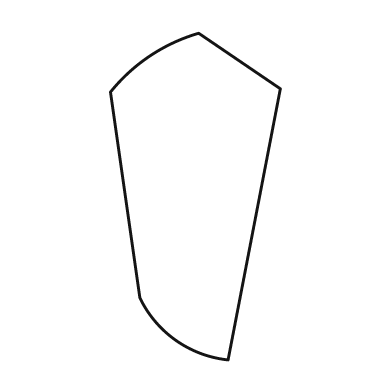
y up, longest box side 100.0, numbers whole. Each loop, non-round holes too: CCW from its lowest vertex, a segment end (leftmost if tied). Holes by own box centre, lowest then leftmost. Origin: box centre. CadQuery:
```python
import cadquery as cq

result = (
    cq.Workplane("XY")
    .moveTo(10.0, -50.0)
    .lineTo(26.0, 33.0)
    .lineTo(1.0, 50.0)
    .threePointArc((-14.0, 43.0), (-26.0, 32.0))
    .lineTo(-17.0, -31.0)
    .threePointArc((-6.0, -44.0), (10.0, -50.0))
    .close()
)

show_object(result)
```